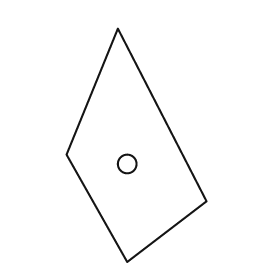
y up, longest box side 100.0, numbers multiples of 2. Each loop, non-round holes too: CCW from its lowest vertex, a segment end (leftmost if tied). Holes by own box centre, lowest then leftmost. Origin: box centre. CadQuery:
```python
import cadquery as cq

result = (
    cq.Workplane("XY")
    .moveTo(-4.0, -50.0)
    .lineTo(30.0, -24.0)
    .lineTo(-8.0, 50.0)
    .lineTo(-30.0, -4.0)
    .close()
    .moveTo(-4.0, -8.0)
    .circle(4.0)
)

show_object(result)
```